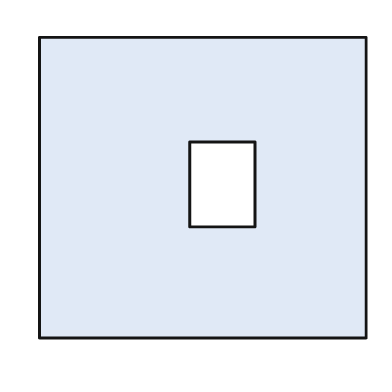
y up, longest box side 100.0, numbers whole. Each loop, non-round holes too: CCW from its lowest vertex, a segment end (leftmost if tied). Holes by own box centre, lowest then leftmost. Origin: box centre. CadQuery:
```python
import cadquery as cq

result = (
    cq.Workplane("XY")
    .moveTo(-50.0, -46.0)
    .lineTo(50.0, -46.0)
    .lineTo(50.0, 46.0)
    .lineTo(-50.0, 46.0)
    .close()
    .moveTo(-4.0, -12.0)
    .lineTo(16.0, -12.0)
    .lineTo(16.0, 14.0)
    .lineTo(-4.0, 14.0)
    .close()
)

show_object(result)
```